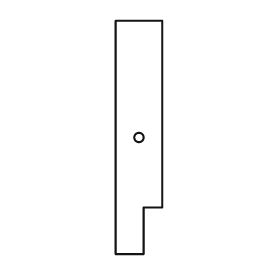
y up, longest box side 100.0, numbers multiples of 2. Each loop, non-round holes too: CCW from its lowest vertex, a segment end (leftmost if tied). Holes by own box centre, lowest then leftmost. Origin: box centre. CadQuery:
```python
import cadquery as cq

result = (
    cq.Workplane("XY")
    .moveTo(-10.0, -50.0)
    .lineTo(2.0, -50.0)
    .lineTo(2.0, -30.0)
    .lineTo(10.0, -30.0)
    .lineTo(10.0, 50.0)
    .lineTo(-10.0, 50.0)
    .close()
    .moveTo(0.0, 0.0)
    .circle(2.0)
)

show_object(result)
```